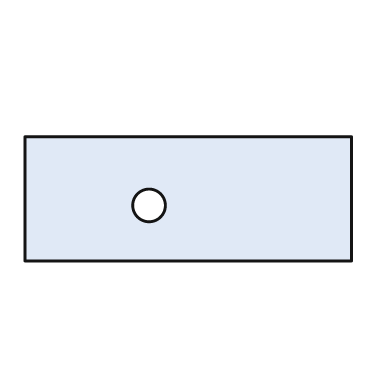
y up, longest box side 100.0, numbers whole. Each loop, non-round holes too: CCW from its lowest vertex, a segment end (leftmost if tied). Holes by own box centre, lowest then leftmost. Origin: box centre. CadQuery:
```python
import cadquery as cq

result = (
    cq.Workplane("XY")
    .moveTo(-50.0, -19.0)
    .lineTo(50.0, -19.0)
    .lineTo(50.0, 19.0)
    .lineTo(-50.0, 19.0)
    .close()
    .moveTo(-12.0, -2.0)
    .circle(5.0)
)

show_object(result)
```